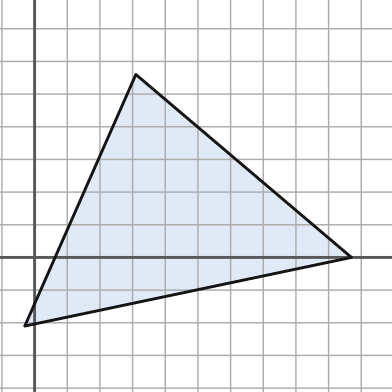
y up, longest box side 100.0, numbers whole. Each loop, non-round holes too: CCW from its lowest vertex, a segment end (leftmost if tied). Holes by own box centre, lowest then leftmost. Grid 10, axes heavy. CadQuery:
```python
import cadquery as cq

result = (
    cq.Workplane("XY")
    .moveTo(-3.0, -21.0)
    .lineTo(97.0, 0.0)
    .lineTo(31.0, 56.0)
    .close()
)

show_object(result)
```